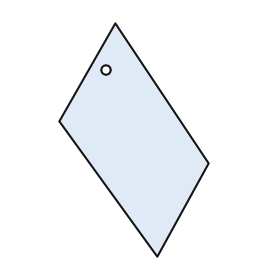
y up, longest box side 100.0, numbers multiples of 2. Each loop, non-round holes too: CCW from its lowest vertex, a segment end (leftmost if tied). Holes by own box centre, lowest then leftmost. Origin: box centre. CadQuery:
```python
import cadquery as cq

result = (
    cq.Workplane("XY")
    .moveTo(10.0, -50.0)
    .lineTo(32.0, -10.0)
    .lineTo(-8.0, 50.0)
    .lineTo(-32.0, 8.0)
    .close()
    .moveTo(-12.0, 30.0)
    .circle(2.0)
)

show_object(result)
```